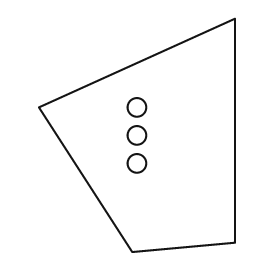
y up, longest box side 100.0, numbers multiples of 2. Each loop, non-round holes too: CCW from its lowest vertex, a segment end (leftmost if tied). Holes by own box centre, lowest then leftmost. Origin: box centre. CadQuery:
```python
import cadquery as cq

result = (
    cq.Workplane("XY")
    .moveTo(-2.0, -50.0)
    .lineTo(42.0, -46.0)
    .lineTo(42.0, 50.0)
    .lineTo(-42.0, 12.0)
    .close()
    .moveTo(0.0, -12.0)
    .circle(4.0)
    .moveTo(0.0, 0.0)
    .circle(4.0)
    .moveTo(0.0, 12.0)
    .circle(4.0)
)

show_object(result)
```